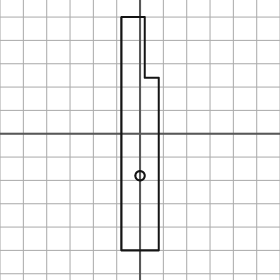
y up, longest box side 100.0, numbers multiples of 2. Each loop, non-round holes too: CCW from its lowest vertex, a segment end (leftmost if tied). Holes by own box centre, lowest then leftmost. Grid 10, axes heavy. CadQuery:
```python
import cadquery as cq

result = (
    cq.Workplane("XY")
    .moveTo(-8.0, -50.0)
    .lineTo(8.0, -50.0)
    .lineTo(8.0, 24.0)
    .lineTo(2.0, 24.0)
    .lineTo(2.0, 50.0)
    .lineTo(-8.0, 50.0)
    .close()
    .moveTo(0.0, -18.0)
    .circle(2.0)
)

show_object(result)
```